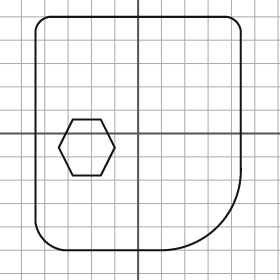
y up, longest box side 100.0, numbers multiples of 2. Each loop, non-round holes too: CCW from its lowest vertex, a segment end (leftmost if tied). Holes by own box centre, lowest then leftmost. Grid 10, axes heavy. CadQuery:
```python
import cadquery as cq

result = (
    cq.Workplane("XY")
    .moveTo(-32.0, -50.0)
    .lineTo(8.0, -50.0)
    .threePointArc((34.0, -40.0), (44.0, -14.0))
    .lineTo(44.0, 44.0)
    .threePointArc((42.0, 48.0), (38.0, 50.0))
    .lineTo(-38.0, 50.0)
    .threePointArc((-42.0, 48.0), (-44.0, 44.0))
    .lineTo(-44.0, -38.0)
    .threePointArc((-40.0, -46.0), (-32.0, -50.0))
    .close()
    .moveTo(-28.0, -18.0)
    .lineTo(-16.0, -18.0)
    .lineTo(-10.0, -6.0)
    .lineTo(-16.0, 6.0)
    .lineTo(-28.0, 6.0)
    .lineTo(-34.0, -6.0)
    .close()
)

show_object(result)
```